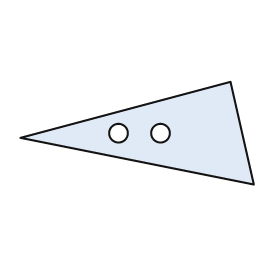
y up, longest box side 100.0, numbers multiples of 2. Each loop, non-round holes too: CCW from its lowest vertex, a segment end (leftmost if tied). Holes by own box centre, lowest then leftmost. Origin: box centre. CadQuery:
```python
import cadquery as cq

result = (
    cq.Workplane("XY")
    .moveTo(50.0, -22.0)
    .lineTo(40.0, 22.0)
    .lineTo(-50.0, -2.0)
    .close()
    .moveTo(-8.0, 0.0)
    .circle(4.0)
    .moveTo(10.0, 0.0)
    .circle(4.0)
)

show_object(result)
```